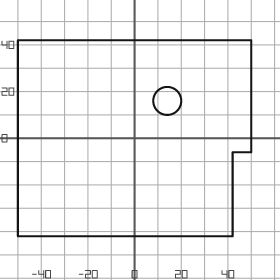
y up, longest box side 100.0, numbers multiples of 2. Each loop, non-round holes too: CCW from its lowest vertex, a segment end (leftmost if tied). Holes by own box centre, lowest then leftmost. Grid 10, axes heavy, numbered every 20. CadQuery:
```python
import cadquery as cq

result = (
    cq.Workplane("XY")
    .moveTo(-50.0, -42.0)
    .lineTo(42.0, -42.0)
    .lineTo(42.0, -6.0)
    .lineTo(50.0, -6.0)
    .lineTo(50.0, 42.0)
    .lineTo(-50.0, 42.0)
    .close()
    .moveTo(14.0, 16.0)
    .circle(6.0)
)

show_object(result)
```